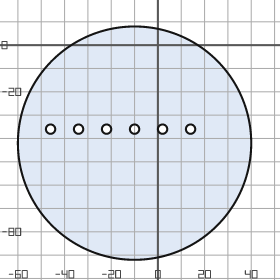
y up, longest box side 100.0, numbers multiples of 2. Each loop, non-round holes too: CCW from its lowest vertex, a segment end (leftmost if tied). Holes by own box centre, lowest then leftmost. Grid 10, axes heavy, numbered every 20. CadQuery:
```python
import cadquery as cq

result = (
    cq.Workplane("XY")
    .moveTo(-10.0, -42.0)
    .circle(50.0)
    .moveTo(-46.0, -36.0)
    .circle(2.0)
    .moveTo(-34.0, -36.0)
    .circle(2.0)
    .moveTo(-22.0, -36.0)
    .circle(2.0)
    .moveTo(-10.0, -36.0)
    .circle(2.0)
    .moveTo(2.0, -36.0)
    .circle(2.0)
    .moveTo(14.0, -36.0)
    .circle(2.0)
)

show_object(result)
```